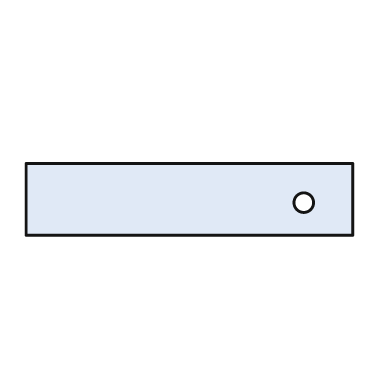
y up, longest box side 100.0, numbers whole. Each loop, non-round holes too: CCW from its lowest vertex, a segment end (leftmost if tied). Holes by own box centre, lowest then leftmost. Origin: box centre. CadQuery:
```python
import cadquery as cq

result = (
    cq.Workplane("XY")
    .moveTo(-50.0, -11.0)
    .lineTo(50.0, -11.0)
    .lineTo(50.0, 11.0)
    .lineTo(-50.0, 11.0)
    .close()
    .moveTo(35.0, -1.0)
    .circle(3.0)
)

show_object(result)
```